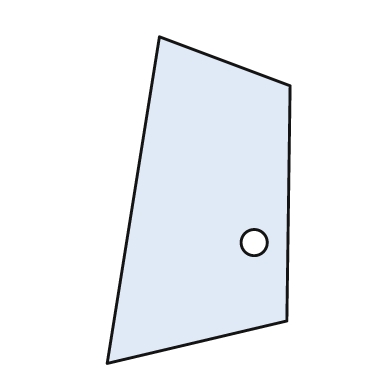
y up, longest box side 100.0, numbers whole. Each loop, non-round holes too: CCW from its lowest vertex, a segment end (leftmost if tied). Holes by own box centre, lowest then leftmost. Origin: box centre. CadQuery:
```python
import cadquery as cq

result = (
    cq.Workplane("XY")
    .moveTo(-28.0, -50.0)
    .lineTo(27.0, -37.0)
    .lineTo(28.0, 35.0)
    .lineTo(-12.0, 50.0)
    .close()
    .moveTo(17.0, -13.0)
    .circle(4.0)
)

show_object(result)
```